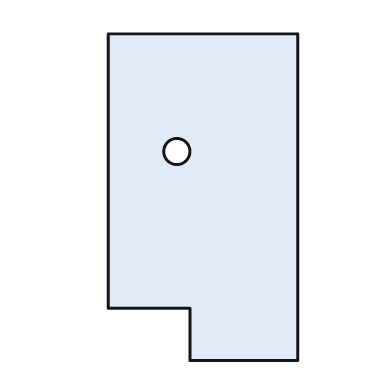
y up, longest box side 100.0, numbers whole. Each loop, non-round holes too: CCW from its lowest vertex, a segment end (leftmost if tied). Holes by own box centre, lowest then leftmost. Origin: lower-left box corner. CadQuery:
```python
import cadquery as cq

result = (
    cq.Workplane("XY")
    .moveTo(25.0, 0.0)
    .lineTo(58.0, 0.0)
    .lineTo(58.0, 100.0)
    .lineTo(0.0, 100.0)
    .lineTo(0.0, 16.0)
    .lineTo(25.0, 16.0)
    .close()
    .moveTo(21.0, 64.0)
    .circle(4.0)
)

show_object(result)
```